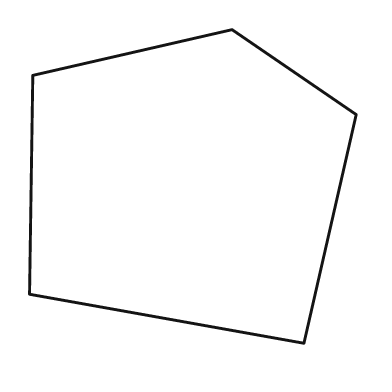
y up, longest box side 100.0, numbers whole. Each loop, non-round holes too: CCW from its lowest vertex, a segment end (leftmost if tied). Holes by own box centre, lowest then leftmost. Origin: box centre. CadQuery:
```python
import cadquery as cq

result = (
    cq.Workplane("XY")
    .moveTo(34.0, -48.0)
    .lineTo(50.0, 22.0)
    .lineTo(12.0, 48.0)
    .lineTo(-49.0, 34.0)
    .lineTo(-50.0, -33.0)
    .close()
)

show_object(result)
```